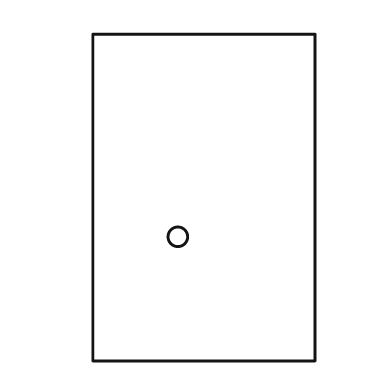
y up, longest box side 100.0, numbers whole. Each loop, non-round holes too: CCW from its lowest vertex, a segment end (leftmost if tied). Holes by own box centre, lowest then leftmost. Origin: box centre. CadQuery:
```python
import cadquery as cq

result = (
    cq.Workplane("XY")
    .moveTo(-34.0, -50.0)
    .lineTo(34.0, -50.0)
    .lineTo(34.0, 50.0)
    .lineTo(-34.0, 50.0)
    .close()
    .moveTo(-8.0, -12.0)
    .circle(3.0)
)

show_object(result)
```